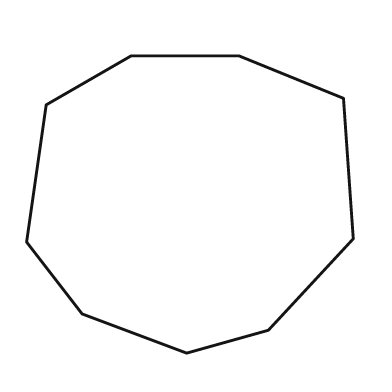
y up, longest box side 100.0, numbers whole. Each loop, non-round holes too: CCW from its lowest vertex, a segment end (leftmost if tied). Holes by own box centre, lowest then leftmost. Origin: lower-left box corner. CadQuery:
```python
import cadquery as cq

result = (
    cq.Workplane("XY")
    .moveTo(49.0, 0.0)
    .lineTo(74.0, 7.0)
    .lineTo(100.0, 35.0)
    .lineTo(97.0, 78.0)
    .lineTo(65.0, 91.0)
    .lineTo(32.0, 91.0)
    .lineTo(6.0, 76.0)
    .lineTo(0.0, 34.0)
    .lineTo(17.0, 12.0)
    .close()
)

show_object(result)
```